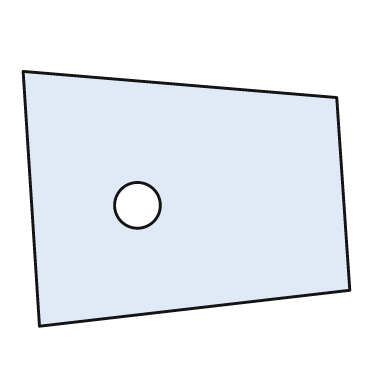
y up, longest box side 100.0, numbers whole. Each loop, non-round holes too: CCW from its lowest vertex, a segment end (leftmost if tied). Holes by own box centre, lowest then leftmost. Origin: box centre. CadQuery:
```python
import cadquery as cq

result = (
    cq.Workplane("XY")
    .moveTo(-45.0, -39.0)
    .lineTo(50.0, -28.0)
    .lineTo(46.0, 31.0)
    .lineTo(-50.0, 39.0)
    .close()
    .moveTo(-15.0, -2.0)
    .circle(7.0)
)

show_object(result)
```